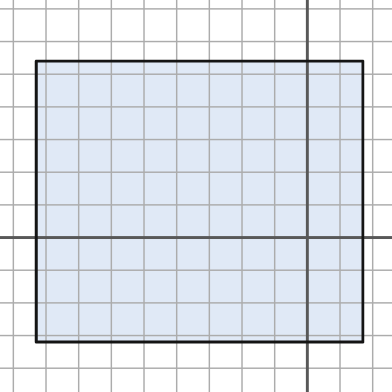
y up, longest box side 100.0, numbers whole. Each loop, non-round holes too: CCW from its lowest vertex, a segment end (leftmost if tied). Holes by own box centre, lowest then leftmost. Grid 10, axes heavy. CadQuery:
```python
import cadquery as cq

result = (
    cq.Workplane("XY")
    .moveTo(-83.0, -32.0)
    .lineTo(17.0, -32.0)
    .lineTo(17.0, 54.0)
    .lineTo(-83.0, 54.0)
    .close()
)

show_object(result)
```